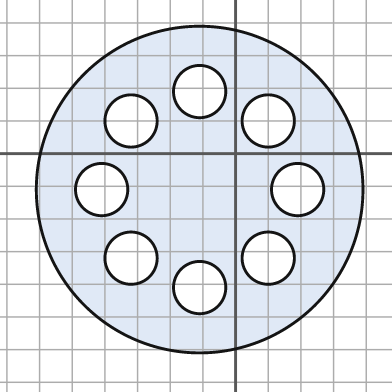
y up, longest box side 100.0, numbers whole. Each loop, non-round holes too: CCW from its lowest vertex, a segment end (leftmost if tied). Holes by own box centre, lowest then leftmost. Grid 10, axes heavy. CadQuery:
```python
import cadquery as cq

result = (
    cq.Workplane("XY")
    .moveTo(-11.0, -11.0)
    .circle(50.0)
    .moveTo(-11.0, -41.0)
    .circle(8.0)
    .moveTo(-32.0, -32.0)
    .circle(8.0)
    .moveTo(10.0, -32.0)
    .circle(8.0)
    .moveTo(-41.0, -11.0)
    .circle(8.0)
    .moveTo(19.0, -11.0)
    .circle(8.0)
    .moveTo(-32.0, 10.0)
    .circle(8.0)
    .moveTo(10.0, 10.0)
    .circle(8.0)
    .moveTo(-11.0, 19.0)
    .circle(8.0)
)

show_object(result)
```